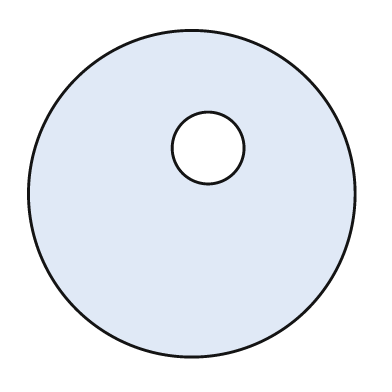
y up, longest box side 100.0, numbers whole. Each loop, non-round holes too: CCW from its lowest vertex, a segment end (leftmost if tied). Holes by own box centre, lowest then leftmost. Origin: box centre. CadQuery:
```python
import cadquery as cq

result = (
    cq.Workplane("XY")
    .moveTo(0.0, 0.0)
    .circle(50.0)
    .moveTo(5.0, 14.0)
    .circle(11.0)
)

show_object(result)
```